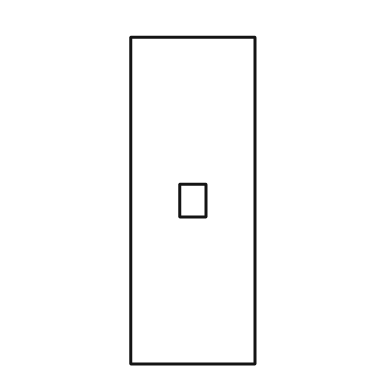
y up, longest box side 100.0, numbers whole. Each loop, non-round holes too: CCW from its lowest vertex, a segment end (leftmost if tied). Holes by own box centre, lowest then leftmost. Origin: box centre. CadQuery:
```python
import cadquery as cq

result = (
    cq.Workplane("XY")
    .moveTo(-19.0, -50.0)
    .lineTo(19.0, -50.0)
    .lineTo(19.0, 50.0)
    .lineTo(-19.0, 50.0)
    .close()
    .moveTo(-4.0, -5.0)
    .lineTo(4.0, -5.0)
    .lineTo(4.0, 5.0)
    .lineTo(-4.0, 5.0)
    .close()
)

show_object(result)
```